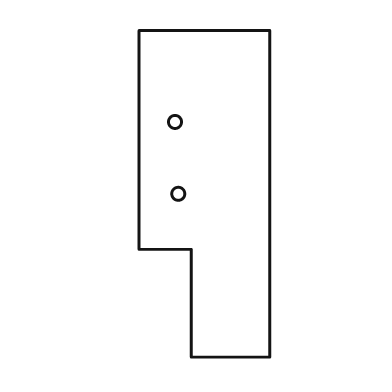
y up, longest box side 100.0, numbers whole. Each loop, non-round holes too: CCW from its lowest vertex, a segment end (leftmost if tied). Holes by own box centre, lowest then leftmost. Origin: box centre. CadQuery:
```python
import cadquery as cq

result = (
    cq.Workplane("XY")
    .moveTo(-4.0, -50.0)
    .lineTo(20.0, -50.0)
    .lineTo(20.0, 50.0)
    .lineTo(-20.0, 50.0)
    .lineTo(-20.0, -17.0)
    .lineTo(-4.0, -17.0)
    .close()
    .moveTo(-8.0, 0.0)
    .circle(2.0)
    .moveTo(-9.0, 22.0)
    .circle(2.0)
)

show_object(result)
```